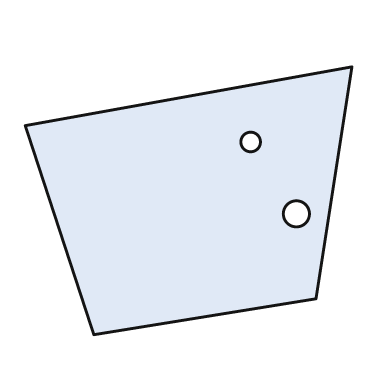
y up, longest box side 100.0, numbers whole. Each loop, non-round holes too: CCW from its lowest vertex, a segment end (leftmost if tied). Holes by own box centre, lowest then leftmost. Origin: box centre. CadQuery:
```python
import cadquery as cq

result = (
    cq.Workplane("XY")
    .moveTo(-29.0, -41.0)
    .lineTo(39.0, -30.0)
    .lineTo(50.0, 41.0)
    .lineTo(-50.0, 23.0)
    .close()
    .moveTo(33.0, -4.0)
    .circle(4.0)
    .moveTo(19.0, 18.0)
    .circle(3.0)
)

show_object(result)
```